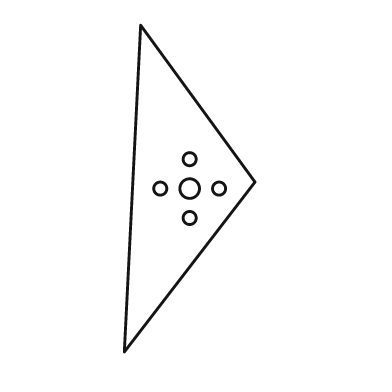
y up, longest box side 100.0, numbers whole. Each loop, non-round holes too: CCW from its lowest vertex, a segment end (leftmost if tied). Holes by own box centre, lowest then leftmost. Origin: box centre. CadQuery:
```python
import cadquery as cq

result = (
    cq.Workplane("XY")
    .moveTo(-20.0, -50.0)
    .lineTo(20.0, 2.0)
    .lineTo(-15.0, 50.0)
    .close()
    .moveTo(0.0, -9.0)
    .circle(2.0)
    .moveTo(-9.0, 0.0)
    .circle(2.0)
    .moveTo(0.0, 0.0)
    .circle(3.0)
    .moveTo(9.0, 0.0)
    .circle(2.0)
    .moveTo(0.0, 9.0)
    .circle(2.0)
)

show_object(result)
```